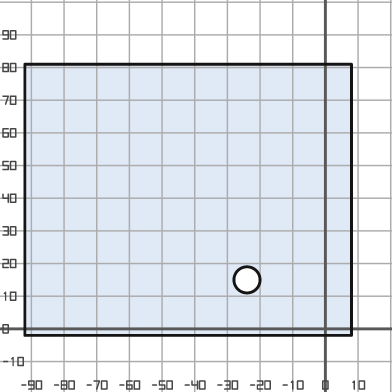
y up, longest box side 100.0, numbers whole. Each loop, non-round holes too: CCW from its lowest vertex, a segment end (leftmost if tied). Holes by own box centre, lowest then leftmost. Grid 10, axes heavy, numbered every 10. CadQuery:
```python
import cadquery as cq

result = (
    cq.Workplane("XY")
    .moveTo(-92.0, -2.0)
    .lineTo(8.0, -2.0)
    .lineTo(8.0, 81.0)
    .lineTo(-92.0, 81.0)
    .close()
    .moveTo(-24.0, 15.0)
    .circle(4.0)
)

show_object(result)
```